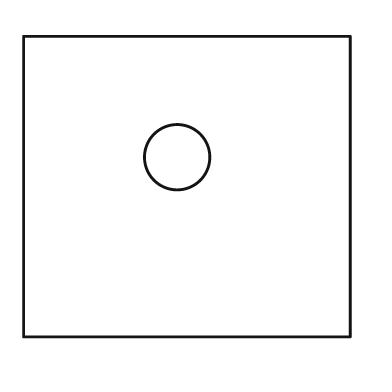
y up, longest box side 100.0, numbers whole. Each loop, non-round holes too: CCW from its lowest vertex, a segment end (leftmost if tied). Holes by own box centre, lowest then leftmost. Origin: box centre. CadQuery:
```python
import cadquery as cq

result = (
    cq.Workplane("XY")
    .moveTo(-50.0, -46.0)
    .lineTo(50.0, -46.0)
    .lineTo(50.0, 46.0)
    .lineTo(-50.0, 46.0)
    .close()
    .moveTo(-3.0, 9.0)
    .circle(10.0)
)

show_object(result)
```